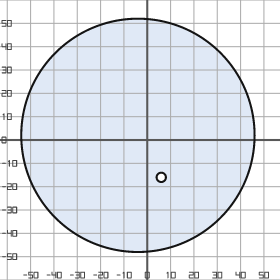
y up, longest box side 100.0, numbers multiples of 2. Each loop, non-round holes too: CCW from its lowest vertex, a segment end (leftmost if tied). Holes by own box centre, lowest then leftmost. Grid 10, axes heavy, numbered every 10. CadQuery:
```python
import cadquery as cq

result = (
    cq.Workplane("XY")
    .moveTo(-4.0, 2.0)
    .circle(50.0)
    .moveTo(6.0, -16.0)
    .circle(2.0)
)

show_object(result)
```